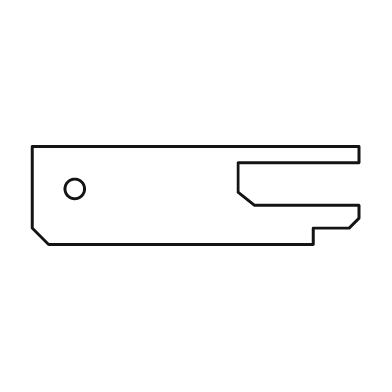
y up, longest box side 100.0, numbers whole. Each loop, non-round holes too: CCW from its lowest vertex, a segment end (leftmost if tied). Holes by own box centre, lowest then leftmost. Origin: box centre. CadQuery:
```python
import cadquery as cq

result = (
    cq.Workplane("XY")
    .moveTo(-45.0, -15.0)
    .lineTo(36.0, -15.0)
    .lineTo(36.0, -10.0)
    .lineTo(47.0, -10.0)
    .lineTo(50.0, -7.0)
    .lineTo(50.0, -3.0)
    .lineTo(18.0, -3.0)
    .lineTo(13.0, 1.0)
    .lineTo(13.0, 10.0)
    .lineTo(50.0, 10.0)
    .lineTo(50.0, 15.0)
    .lineTo(-50.0, 15.0)
    .lineTo(-50.0, -10.0)
    .close()
    .moveTo(-37.0, 2.0)
    .circle(3.0)
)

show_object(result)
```